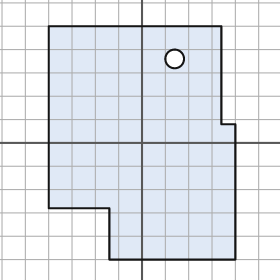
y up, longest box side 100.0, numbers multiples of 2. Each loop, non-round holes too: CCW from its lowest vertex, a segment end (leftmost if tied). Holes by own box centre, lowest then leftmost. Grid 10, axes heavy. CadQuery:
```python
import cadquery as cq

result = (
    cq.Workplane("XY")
    .moveTo(-14.0, -50.0)
    .lineTo(40.0, -50.0)
    .lineTo(40.0, 8.0)
    .lineTo(34.0, 8.0)
    .lineTo(34.0, 50.0)
    .lineTo(-40.0, 50.0)
    .lineTo(-40.0, -28.0)
    .lineTo(-14.0, -28.0)
    .close()
    .moveTo(14.0, 36.0)
    .circle(4.0)
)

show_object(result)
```